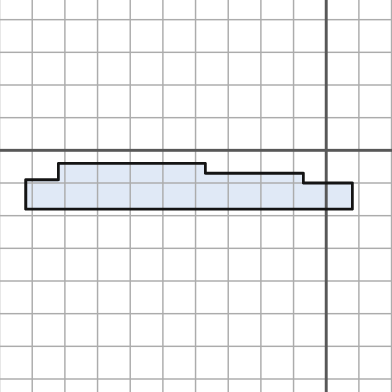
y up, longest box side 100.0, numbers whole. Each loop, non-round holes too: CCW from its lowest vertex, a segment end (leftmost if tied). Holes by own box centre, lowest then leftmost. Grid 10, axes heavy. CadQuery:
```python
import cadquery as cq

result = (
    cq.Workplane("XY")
    .moveTo(-92.0, -18.0)
    .lineTo(8.0, -18.0)
    .lineTo(8.0, -10.0)
    .lineTo(-7.0, -10.0)
    .lineTo(-7.0, -7.0)
    .lineTo(-37.0, -7.0)
    .lineTo(-37.0, -4.0)
    .lineTo(-82.0, -4.0)
    .lineTo(-82.0, -9.0)
    .lineTo(-92.0, -9.0)
    .close()
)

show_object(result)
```